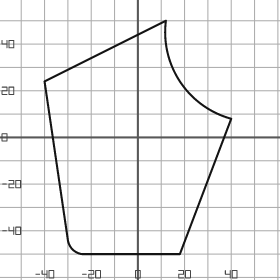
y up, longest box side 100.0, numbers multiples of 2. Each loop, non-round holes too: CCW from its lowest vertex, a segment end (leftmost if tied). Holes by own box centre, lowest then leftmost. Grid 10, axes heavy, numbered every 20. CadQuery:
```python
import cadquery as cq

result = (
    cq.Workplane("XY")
    .moveTo(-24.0, -50.0)
    .lineTo(18.0, -50.0)
    .lineTo(40.0, 8.0)
    .threePointArc((18.0, 24.0), (12.0, 50.0))
    .lineTo(-40.0, 24.0)
    .lineTo(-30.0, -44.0)
    .threePointArc((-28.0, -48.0), (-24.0, -50.0))
    .close()
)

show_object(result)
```